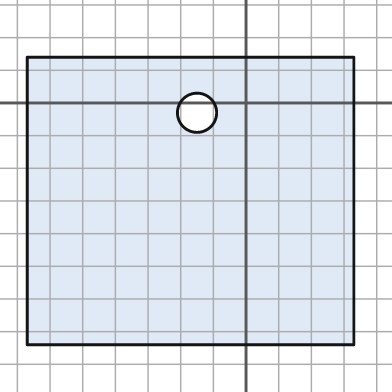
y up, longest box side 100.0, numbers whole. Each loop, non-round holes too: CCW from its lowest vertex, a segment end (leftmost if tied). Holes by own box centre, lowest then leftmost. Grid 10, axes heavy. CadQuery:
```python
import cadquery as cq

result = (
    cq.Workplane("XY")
    .moveTo(-67.0, -74.0)
    .lineTo(33.0, -74.0)
    .lineTo(33.0, 14.0)
    .lineTo(-67.0, 14.0)
    .close()
    .moveTo(-15.0, -3.0)
    .circle(6.0)
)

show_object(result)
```